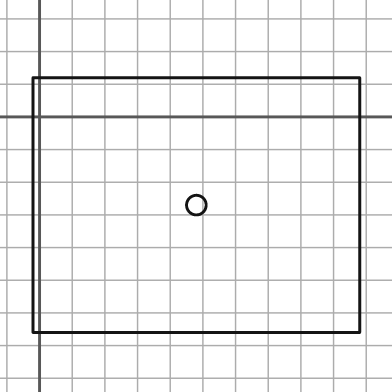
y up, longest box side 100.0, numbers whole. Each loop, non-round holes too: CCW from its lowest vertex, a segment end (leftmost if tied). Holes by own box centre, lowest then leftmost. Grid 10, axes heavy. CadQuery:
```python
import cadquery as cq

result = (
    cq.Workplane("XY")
    .moveTo(-2.0, -66.0)
    .lineTo(98.0, -66.0)
    .lineTo(98.0, 12.0)
    .lineTo(-2.0, 12.0)
    .close()
    .moveTo(48.0, -27.0)
    .circle(3.0)
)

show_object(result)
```